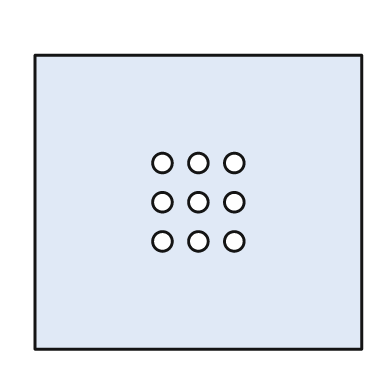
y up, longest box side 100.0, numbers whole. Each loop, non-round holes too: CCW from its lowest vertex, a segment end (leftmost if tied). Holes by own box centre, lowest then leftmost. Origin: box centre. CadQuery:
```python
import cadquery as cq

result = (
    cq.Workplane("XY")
    .moveTo(-50.0, -45.0)
    .lineTo(50.0, -45.0)
    .lineTo(50.0, 45.0)
    .lineTo(-50.0, 45.0)
    .close()
    .moveTo(-11.0, -12.0)
    .circle(3.0)
    .moveTo(0.0, -12.0)
    .circle(3.0)
    .moveTo(11.0, -12.0)
    .circle(3.0)
    .moveTo(-11.0, 0.0)
    .circle(3.0)
    .moveTo(0.0, 0.0)
    .circle(3.0)
    .moveTo(11.0, 0.0)
    .circle(3.0)
    .moveTo(-11.0, 12.0)
    .circle(3.0)
    .moveTo(0.0, 12.0)
    .circle(3.0)
    .moveTo(11.0, 12.0)
    .circle(3.0)
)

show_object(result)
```